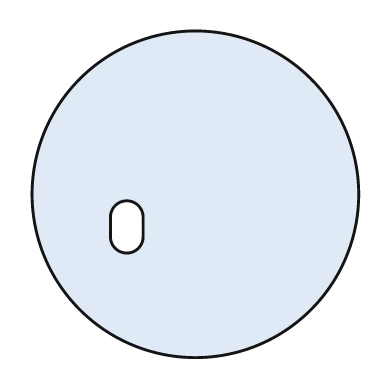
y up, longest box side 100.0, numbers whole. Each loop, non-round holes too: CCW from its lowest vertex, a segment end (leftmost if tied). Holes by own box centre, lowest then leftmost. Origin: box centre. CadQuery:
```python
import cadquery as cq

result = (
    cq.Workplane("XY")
    .moveTo(0.0, 0.0)
    .circle(50.0)
    .moveTo(-26.0, -13.0)
    .threePointArc((-21.0, -18.0), (-16.0, -13.0))
    .lineTo(-16.0, -7.0)
    .threePointArc((-21.0, -2.0), (-26.0, -7.0))
    .close()
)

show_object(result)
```